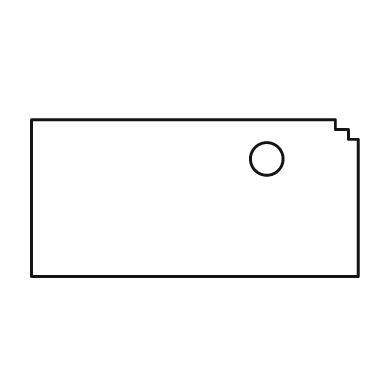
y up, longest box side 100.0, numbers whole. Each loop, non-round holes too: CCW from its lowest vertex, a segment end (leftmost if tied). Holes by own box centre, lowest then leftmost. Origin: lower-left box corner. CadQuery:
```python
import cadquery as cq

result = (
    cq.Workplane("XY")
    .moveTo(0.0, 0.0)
    .lineTo(100.0, 0.0)
    .lineTo(100.0, 42.0)
    .lineTo(97.0, 42.0)
    .lineTo(97.0, 45.0)
    .lineTo(93.0, 45.0)
    .lineTo(93.0, 48.0)
    .lineTo(0.0, 48.0)
    .close()
    .moveTo(72.0, 36.0)
    .circle(5.0)
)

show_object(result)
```